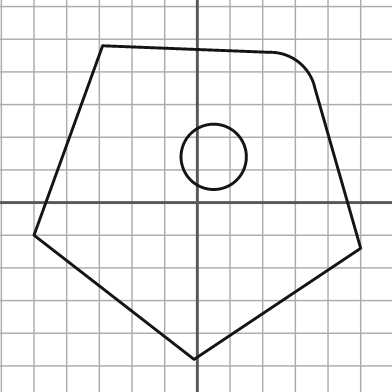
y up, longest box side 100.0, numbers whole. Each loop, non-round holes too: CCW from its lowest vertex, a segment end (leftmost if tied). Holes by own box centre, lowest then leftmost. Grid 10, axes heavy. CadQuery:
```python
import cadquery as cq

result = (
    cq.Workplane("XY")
    .moveTo(-1.0, -48.0)
    .lineTo(50.0, -14.0)
    .lineTo(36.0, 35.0)
    .threePointArc((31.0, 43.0), (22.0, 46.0))
    .lineTo(-29.0, 48.0)
    .lineTo(-50.0, -10.0)
    .close()
    .moveTo(5.0, 14.0)
    .circle(10.0)
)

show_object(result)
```